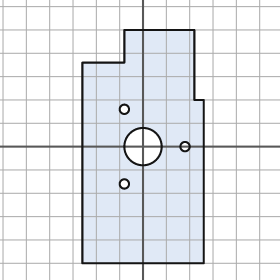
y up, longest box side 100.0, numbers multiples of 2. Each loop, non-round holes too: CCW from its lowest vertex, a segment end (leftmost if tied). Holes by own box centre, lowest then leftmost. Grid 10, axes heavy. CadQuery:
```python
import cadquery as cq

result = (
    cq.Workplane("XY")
    .moveTo(-26.0, -50.0)
    .lineTo(26.0, -50.0)
    .lineTo(26.0, 20.0)
    .lineTo(22.0, 20.0)
    .lineTo(22.0, 50.0)
    .lineTo(-8.0, 50.0)
    .lineTo(-8.0, 36.0)
    .lineTo(-26.0, 36.0)
    .close()
    .moveTo(-8.0, -16.0)
    .circle(2.0)
    .moveTo(0.0, 0.0)
    .circle(8.0)
    .moveTo(18.0, 0.0)
    .circle(2.0)
    .moveTo(-8.0, 16.0)
    .circle(2.0)
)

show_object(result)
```